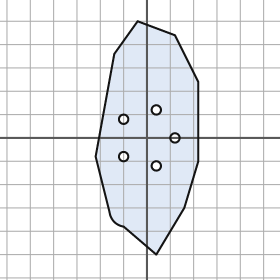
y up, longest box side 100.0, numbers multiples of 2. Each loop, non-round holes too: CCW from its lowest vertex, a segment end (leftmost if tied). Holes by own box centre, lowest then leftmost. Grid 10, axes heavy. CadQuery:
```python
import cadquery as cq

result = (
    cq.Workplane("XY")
    .moveTo(4.0, -50.0)
    .lineTo(16.0, -30.0)
    .lineTo(22.0, -10.0)
    .lineTo(22.0, 24.0)
    .lineTo(12.0, 44.0)
    .lineTo(-4.0, 50.0)
    .lineTo(-14.0, 36.0)
    .lineTo(-22.0, -8.0)
    .lineTo(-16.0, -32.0)
    .threePointArc((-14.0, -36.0), (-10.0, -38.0))
    .close()
    .moveTo(4.0, -12.0)
    .circle(2.0)
    .moveTo(-10.0, -8.0)
    .circle(2.0)
    .moveTo(12.0, 0.0)
    .circle(2.0)
    .moveTo(-10.0, 8.0)
    .circle(2.0)
    .moveTo(4.0, 12.0)
    .circle(2.0)
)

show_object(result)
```